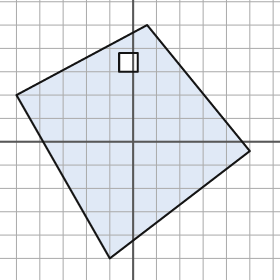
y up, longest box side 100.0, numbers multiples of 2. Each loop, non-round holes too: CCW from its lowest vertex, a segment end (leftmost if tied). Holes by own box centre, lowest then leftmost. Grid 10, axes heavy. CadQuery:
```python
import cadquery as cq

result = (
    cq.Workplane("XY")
    .moveTo(-10.0, -50.0)
    .lineTo(50.0, -4.0)
    .lineTo(6.0, 50.0)
    .lineTo(-50.0, 20.0)
    .close()
    .moveTo(-6.0, 30.0)
    .lineTo(2.0, 30.0)
    .lineTo(2.0, 38.0)
    .lineTo(-6.0, 38.0)
    .close()
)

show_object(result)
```